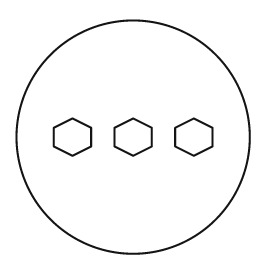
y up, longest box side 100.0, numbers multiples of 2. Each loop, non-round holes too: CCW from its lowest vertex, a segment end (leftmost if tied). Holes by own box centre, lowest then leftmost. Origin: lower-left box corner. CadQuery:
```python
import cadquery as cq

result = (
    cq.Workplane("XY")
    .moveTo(50.0, 50.0)
    .circle(50.0)
    .moveTo(24.0, 42.0)
    .lineTo(32.0, 46.0)
    .lineTo(32.0, 54.0)
    .lineTo(24.0, 58.0)
    .lineTo(16.0, 54.0)
    .lineTo(16.0, 46.0)
    .close()
    .moveTo(50.0, 42.0)
    .lineTo(58.0, 46.0)
    .lineTo(58.0, 54.0)
    .lineTo(50.0, 58.0)
    .lineTo(42.0, 54.0)
    .lineTo(42.0, 46.0)
    .close()
    .moveTo(76.0, 42.0)
    .lineTo(84.0, 46.0)
    .lineTo(84.0, 54.0)
    .lineTo(76.0, 58.0)
    .lineTo(68.0, 54.0)
    .lineTo(68.0, 46.0)
    .close()
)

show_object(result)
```